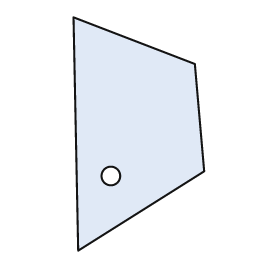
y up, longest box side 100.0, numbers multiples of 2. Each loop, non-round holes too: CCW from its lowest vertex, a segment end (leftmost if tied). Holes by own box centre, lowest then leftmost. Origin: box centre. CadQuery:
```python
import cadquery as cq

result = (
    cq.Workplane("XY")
    .moveTo(-26.0, -50.0)
    .lineTo(28.0, -16.0)
    .lineTo(24.0, 30.0)
    .lineTo(-28.0, 50.0)
    .close()
    .moveTo(-12.0, -18.0)
    .circle(4.0)
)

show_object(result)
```